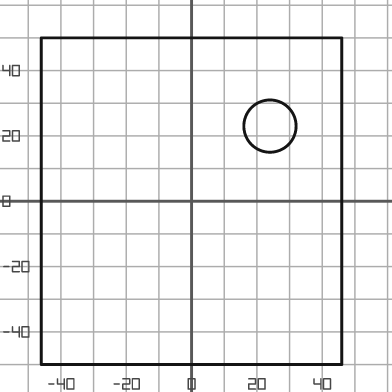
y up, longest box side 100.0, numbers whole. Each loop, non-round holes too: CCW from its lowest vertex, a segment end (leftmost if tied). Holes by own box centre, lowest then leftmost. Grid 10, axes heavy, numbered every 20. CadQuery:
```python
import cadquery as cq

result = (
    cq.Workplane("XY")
    .moveTo(-46.0, -50.0)
    .lineTo(46.0, -50.0)
    .lineTo(46.0, 50.0)
    .lineTo(-46.0, 50.0)
    .close()
    .moveTo(24.0, 23.0)
    .circle(8.0)
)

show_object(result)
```